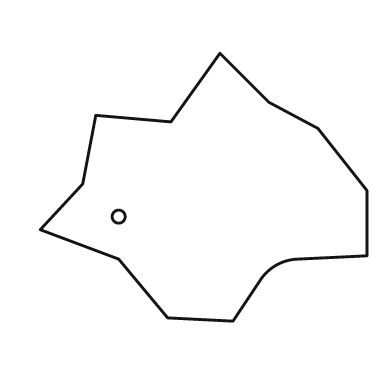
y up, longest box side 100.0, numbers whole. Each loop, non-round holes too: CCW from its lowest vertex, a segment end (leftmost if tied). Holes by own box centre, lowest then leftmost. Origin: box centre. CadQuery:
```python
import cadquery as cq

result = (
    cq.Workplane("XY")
    .moveTo(9.0, -41.0)
    .lineTo(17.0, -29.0)
    .threePointArc((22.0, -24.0), (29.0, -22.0))
    .lineTo(50.0, -21.0)
    .lineTo(50.0, -1.0)
    .lineTo(35.0, 18.0)
    .lineTo(20.0, 26.0)
    .lineTo(5.0, 41.0)
    .lineTo(-10.0, 20.0)
    .lineTo(-33.0, 22.0)
    .lineTo(-37.0, 1.0)
    .lineTo(-50.0, -13.0)
    .lineTo(-26.0, -22.0)
    .lineTo(-11.0, -40.0)
    .close()
    .moveTo(-26.0, -9.0)
    .circle(2.0)
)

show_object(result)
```